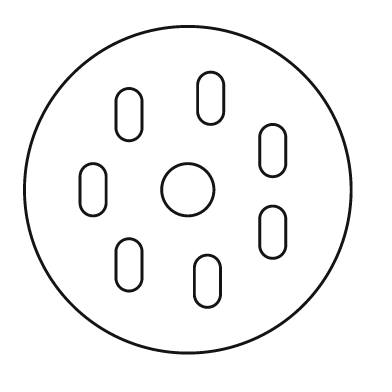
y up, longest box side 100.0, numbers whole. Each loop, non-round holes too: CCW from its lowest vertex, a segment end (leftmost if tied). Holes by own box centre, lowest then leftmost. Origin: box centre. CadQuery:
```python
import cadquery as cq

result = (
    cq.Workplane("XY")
    .moveTo(0.0, 0.0)
    .circle(50.0)
    .moveTo(2.0, -32.0)
    .threePointArc((6.0, -36.0), (10.0, -32.0))
    .lineTo(10.0, -24.0)
    .threePointArc((6.0, -20.0), (2.0, -24.0))
    .close()
    .moveTo(-22.0, -27.0)
    .threePointArc((-18.0, -31.0), (-14.0, -27.0))
    .lineTo(-14.0, -19.0)
    .threePointArc((-18.0, -15.0), (-22.0, -19.0))
    .close()
    .moveTo(22.0, -17.0)
    .threePointArc((26.0, -21.0), (30.0, -17.0))
    .lineTo(30.0, -9.0)
    .threePointArc((26.0, -5.0), (22.0, -9.0))
    .close()
    .moveTo(-33.0, -4.0)
    .threePointArc((-29.0, -8.0), (-25.0, -4.0))
    .lineTo(-25.0, 4.0)
    .threePointArc((-29.0, 8.0), (-33.0, 4.0))
    .close()
    .moveTo(0.0, 0.0)
    .circle(8.0)
    .moveTo(22.0, 8.0)
    .threePointArc((26.0, 4.0), (30.0, 8.0))
    .lineTo(30.0, 16.0)
    .threePointArc((26.0, 20.0), (22.0, 16.0))
    .close()
    .moveTo(-22.0, 19.0)
    .threePointArc((-18.0, 15.0), (-14.0, 19.0))
    .lineTo(-14.0, 27.0)
    .threePointArc((-18.0, 31.0), (-22.0, 27.0))
    .close()
    .moveTo(3.0, 24.0)
    .threePointArc((7.0, 20.0), (11.0, 24.0))
    .lineTo(11.0, 32.0)
    .threePointArc((7.0, 36.0), (3.0, 32.0))
    .close()
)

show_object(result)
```